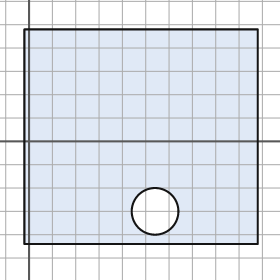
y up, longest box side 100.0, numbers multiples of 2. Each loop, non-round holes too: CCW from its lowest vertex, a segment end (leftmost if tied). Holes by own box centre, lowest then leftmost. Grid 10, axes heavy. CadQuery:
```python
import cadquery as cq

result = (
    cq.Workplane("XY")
    .moveTo(-2.0, -44.0)
    .lineTo(98.0, -44.0)
    .lineTo(98.0, 48.0)
    .lineTo(-2.0, 48.0)
    .close()
    .moveTo(54.0, -30.0)
    .circle(10.0)
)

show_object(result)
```